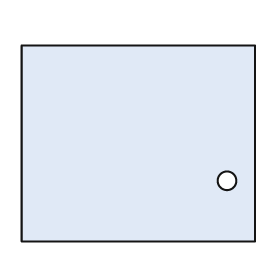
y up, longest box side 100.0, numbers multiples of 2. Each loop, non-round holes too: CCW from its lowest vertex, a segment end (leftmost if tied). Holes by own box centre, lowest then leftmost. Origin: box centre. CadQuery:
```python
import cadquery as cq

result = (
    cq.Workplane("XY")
    .moveTo(-50.0, -42.0)
    .lineTo(50.0, -42.0)
    .lineTo(50.0, 42.0)
    .lineTo(-50.0, 42.0)
    .close()
    .moveTo(38.0, -16.0)
    .circle(4.0)
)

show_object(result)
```